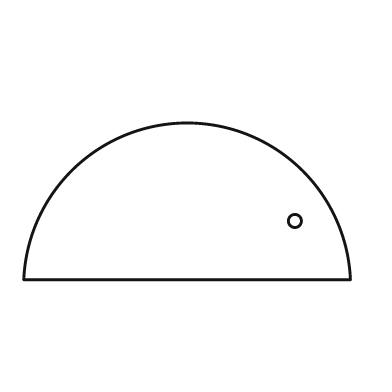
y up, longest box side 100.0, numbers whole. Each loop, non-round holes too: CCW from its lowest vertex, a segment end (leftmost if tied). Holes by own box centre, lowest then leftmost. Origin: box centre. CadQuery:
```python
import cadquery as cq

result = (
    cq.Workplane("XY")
    .moveTo(-50.0, -24.0)
    .lineTo(50.0, -24.0)
    .threePointArc((0.0, 24.0), (-50.0, -24.0))
    .close()
    .moveTo(33.0, -6.0)
    .circle(2.0)
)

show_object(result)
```